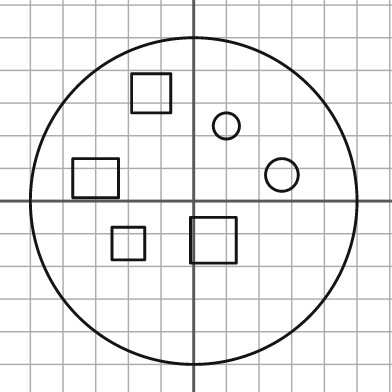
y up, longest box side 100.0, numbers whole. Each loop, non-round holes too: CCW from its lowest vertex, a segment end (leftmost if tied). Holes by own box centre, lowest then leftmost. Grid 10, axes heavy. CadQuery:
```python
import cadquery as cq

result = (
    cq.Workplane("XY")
    .moveTo(0.0, 0.0)
    .circle(50.0)
    .moveTo(-25.0, -18.0)
    .lineTo(-15.0, -18.0)
    .lineTo(-15.0, -8.0)
    .lineTo(-25.0, -8.0)
    .close()
    .moveTo(-1.0, -19.0)
    .lineTo(13.0, -19.0)
    .lineTo(13.0, -5.0)
    .lineTo(-1.0, -5.0)
    .close()
    .moveTo(-37.0, 1.0)
    .lineTo(-23.0, 1.0)
    .lineTo(-23.0, 13.0)
    .lineTo(-37.0, 13.0)
    .close()
    .moveTo(27.0, 8.0)
    .circle(5.0)
    .moveTo(10.0, 23.0)
    .circle(4.0)
    .moveTo(-19.0, 27.0)
    .lineTo(-7.0, 27.0)
    .lineTo(-7.0, 39.0)
    .lineTo(-19.0, 39.0)
    .close()
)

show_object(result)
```